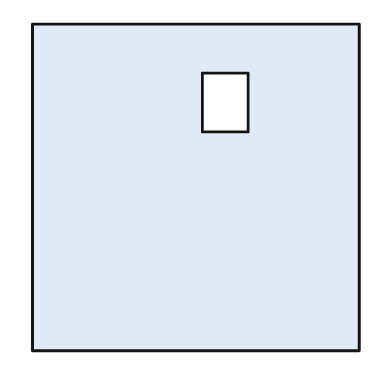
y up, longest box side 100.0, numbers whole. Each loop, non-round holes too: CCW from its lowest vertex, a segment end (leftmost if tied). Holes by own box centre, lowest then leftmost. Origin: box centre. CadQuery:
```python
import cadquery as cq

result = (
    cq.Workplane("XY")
    .moveTo(-50.0, -50.0)
    .lineTo(50.0, -50.0)
    .lineTo(50.0, 50.0)
    .lineTo(-50.0, 50.0)
    .close()
    .moveTo(2.0, 17.0)
    .lineTo(16.0, 17.0)
    .lineTo(16.0, 35.0)
    .lineTo(2.0, 35.0)
    .close()
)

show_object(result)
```